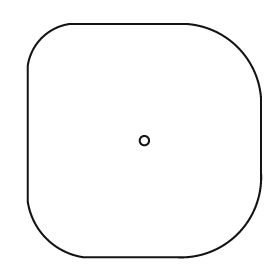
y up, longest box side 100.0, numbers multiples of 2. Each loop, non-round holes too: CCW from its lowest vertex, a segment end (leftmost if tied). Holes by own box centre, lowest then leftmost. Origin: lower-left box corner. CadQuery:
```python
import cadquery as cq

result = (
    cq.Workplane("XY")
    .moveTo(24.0, 0.0)
    .lineTo(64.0, 0.0)
    .threePointArc((90.0, 10.0), (100.0, 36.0))
    .lineTo(100.0, 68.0)
    .threePointArc((90.0, 90.0), (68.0, 100.0))
    .lineTo(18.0, 100.0)
    .threePointArc((6.0, 94.0), (0.0, 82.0))
    .lineTo(0.0, 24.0)
    .threePointArc((8.0, 8.0), (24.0, 0.0))
    .close()
    .moveTo(50.0, 50.0)
    .circle(2.0)
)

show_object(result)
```